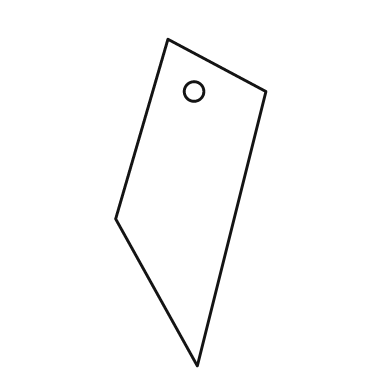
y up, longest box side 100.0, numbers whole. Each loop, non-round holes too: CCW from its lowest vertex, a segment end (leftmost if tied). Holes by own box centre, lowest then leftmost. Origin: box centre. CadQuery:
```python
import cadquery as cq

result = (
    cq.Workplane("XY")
    .moveTo(2.0, -50.0)
    .lineTo(23.0, 34.0)
    .lineTo(-7.0, 50.0)
    .lineTo(-23.0, -5.0)
    .close()
    .moveTo(1.0, 34.0)
    .circle(3.0)
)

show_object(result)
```